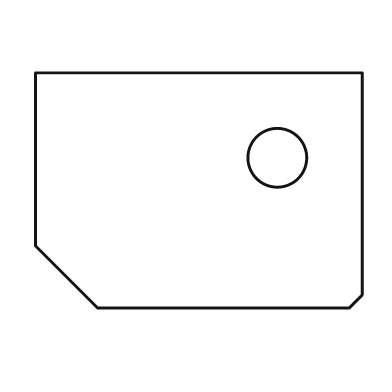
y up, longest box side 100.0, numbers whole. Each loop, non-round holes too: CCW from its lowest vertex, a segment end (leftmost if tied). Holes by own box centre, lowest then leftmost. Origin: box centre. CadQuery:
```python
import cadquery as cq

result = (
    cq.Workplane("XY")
    .moveTo(-31.0, -36.0)
    .lineTo(46.0, -36.0)
    .lineTo(50.0, -32.0)
    .lineTo(50.0, 36.0)
    .lineTo(-50.0, 36.0)
    .lineTo(-50.0, -17.0)
    .close()
    .moveTo(24.0, 10.0)
    .circle(9.0)
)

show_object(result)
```